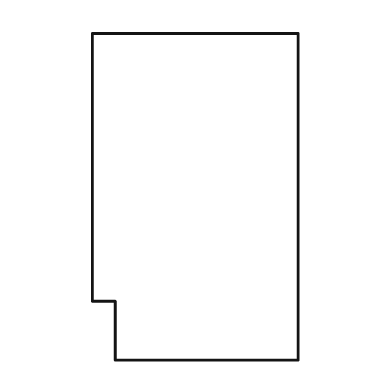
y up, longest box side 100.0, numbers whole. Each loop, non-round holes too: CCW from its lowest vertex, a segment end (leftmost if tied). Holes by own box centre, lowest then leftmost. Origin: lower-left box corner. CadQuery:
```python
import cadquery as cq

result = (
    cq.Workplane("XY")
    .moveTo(7.0, 0.0)
    .lineTo(63.0, 0.0)
    .lineTo(63.0, 100.0)
    .lineTo(0.0, 100.0)
    .lineTo(0.0, 18.0)
    .lineTo(7.0, 18.0)
    .close()
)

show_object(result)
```